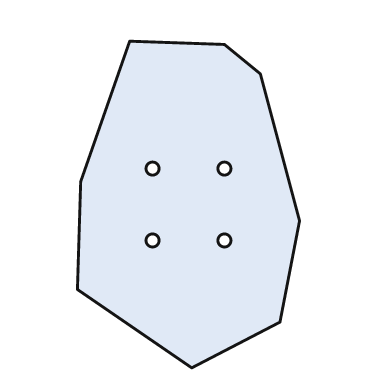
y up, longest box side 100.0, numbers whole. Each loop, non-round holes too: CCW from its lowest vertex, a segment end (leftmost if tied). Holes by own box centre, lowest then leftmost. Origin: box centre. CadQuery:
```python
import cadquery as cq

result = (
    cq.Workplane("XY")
    .moveTo(1.0, -50.0)
    .lineTo(28.0, -36.0)
    .lineTo(34.0, -5.0)
    .lineTo(22.0, 40.0)
    .lineTo(11.0, 49.0)
    .lineTo(-18.0, 50.0)
    .lineTo(-33.0, 7.0)
    .lineTo(-34.0, -26.0)
    .close()
    .moveTo(-11.0, -11.0)
    .circle(2.0)
    .moveTo(11.0, -11.0)
    .circle(2.0)
    .moveTo(-11.0, 11.0)
    .circle(2.0)
    .moveTo(11.0, 11.0)
    .circle(2.0)
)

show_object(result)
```